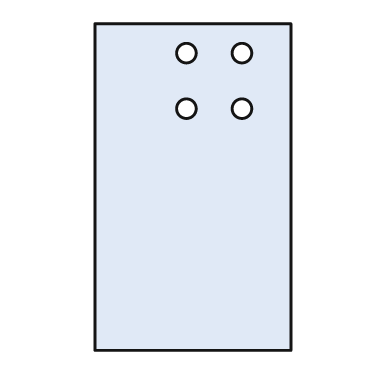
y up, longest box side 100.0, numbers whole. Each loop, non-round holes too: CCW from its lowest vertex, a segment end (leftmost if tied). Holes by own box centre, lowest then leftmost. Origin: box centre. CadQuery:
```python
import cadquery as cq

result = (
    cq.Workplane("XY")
    .moveTo(-30.0, -50.0)
    .lineTo(30.0, -50.0)
    .lineTo(30.0, 50.0)
    .lineTo(-30.0, 50.0)
    .close()
    .moveTo(-2.0, 24.0)
    .circle(3.0)
    .moveTo(15.0, 24.0)
    .circle(3.0)
    .moveTo(-2.0, 41.0)
    .circle(3.0)
    .moveTo(15.0, 41.0)
    .circle(3.0)
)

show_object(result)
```